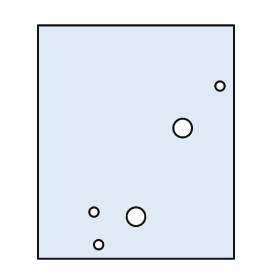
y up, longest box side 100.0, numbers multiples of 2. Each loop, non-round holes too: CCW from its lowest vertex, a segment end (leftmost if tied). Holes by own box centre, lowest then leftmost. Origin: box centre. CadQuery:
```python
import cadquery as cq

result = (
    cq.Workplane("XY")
    .moveTo(-42.0, -50.0)
    .lineTo(42.0, -50.0)
    .lineTo(42.0, 50.0)
    .lineTo(-42.0, 50.0)
    .close()
    .moveTo(-16.0, -44.0)
    .circle(2.0)
    .moveTo(0.0, -32.0)
    .circle(4.0)
    .moveTo(-18.0, -30.0)
    .circle(2.0)
    .moveTo(20.0, 6.0)
    .circle(4.0)
    .moveTo(36.0, 24.0)
    .circle(2.0)
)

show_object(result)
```